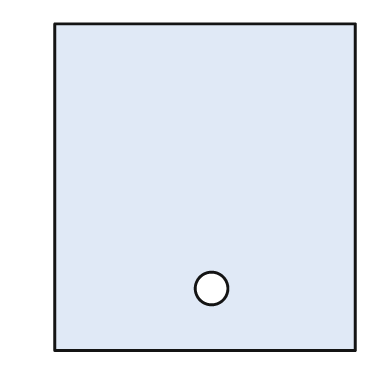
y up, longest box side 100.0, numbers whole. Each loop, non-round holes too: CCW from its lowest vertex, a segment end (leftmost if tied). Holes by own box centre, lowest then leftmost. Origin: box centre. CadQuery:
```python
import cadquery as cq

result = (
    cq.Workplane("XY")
    .moveTo(-46.0, -50.0)
    .lineTo(46.0, -50.0)
    .lineTo(46.0, 50.0)
    .lineTo(-46.0, 50.0)
    .close()
    .moveTo(2.0, -31.0)
    .circle(5.0)
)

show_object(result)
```